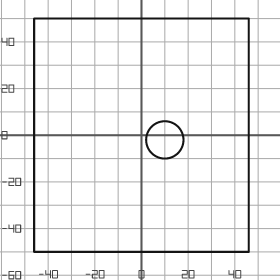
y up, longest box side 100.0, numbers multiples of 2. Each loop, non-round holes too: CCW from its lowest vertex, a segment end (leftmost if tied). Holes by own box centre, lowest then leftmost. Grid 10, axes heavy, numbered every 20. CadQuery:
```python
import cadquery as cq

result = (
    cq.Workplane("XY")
    .moveTo(-46.0, -50.0)
    .lineTo(46.0, -50.0)
    .lineTo(46.0, 50.0)
    .lineTo(-46.0, 50.0)
    .close()
    .moveTo(10.0, -2.0)
    .circle(8.0)
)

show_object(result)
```